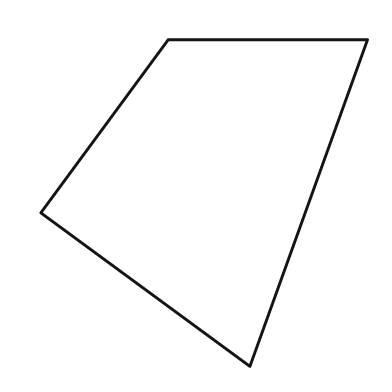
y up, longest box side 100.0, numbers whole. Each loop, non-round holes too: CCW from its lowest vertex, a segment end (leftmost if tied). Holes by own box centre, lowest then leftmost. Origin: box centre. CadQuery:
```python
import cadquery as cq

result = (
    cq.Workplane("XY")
    .moveTo(14.0, -50.0)
    .lineTo(50.0, 50.0)
    .lineTo(-11.0, 50.0)
    .lineTo(-50.0, -3.0)
    .close()
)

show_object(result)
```